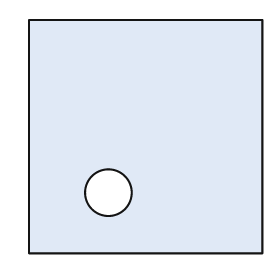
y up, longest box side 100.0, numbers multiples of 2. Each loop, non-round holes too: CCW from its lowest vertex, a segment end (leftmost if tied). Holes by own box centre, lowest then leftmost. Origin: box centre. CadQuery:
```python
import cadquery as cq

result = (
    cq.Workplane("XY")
    .moveTo(-50.0, -50.0)
    .lineTo(50.0, -50.0)
    .lineTo(50.0, 50.0)
    .lineTo(-50.0, 50.0)
    .close()
    .moveTo(-16.0, -24.0)
    .circle(10.0)
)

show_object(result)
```